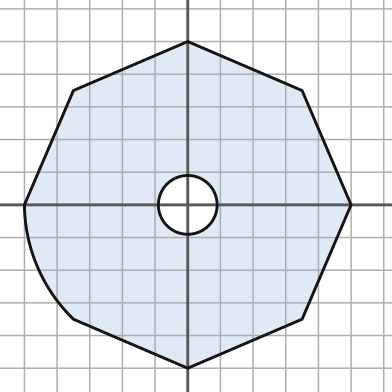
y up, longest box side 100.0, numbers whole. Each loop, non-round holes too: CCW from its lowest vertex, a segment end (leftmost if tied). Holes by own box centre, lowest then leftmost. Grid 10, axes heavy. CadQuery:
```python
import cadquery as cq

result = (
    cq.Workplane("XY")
    .moveTo(0.0, -50.0)
    .lineTo(35.0, -35.0)
    .lineTo(50.0, 0.0)
    .lineTo(35.0, 35.0)
    .lineTo(0.0, 50.0)
    .lineTo(-35.0, 35.0)
    .lineTo(-50.0, 0.0)
    .threePointArc((-46.0, -19.0), (-35.0, -35.0))
    .close()
    .moveTo(0.0, 0.0)
    .circle(9.0)
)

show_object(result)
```